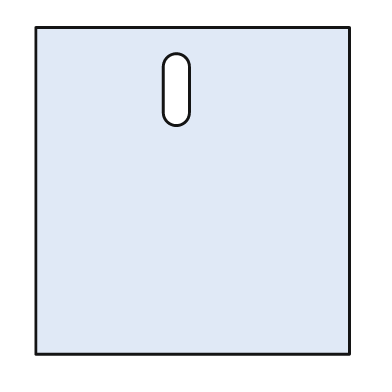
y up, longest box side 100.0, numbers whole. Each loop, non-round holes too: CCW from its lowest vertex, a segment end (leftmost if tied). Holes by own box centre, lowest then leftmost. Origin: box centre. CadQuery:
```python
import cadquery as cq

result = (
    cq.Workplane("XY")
    .moveTo(-48.0, -50.0)
    .lineTo(48.0, -50.0)
    .lineTo(48.0, 50.0)
    .lineTo(-48.0, 50.0)
    .close()
    .moveTo(-9.0, 24.0)
    .threePointArc((-5.0, 20.0), (-1.0, 24.0))
    .lineTo(-1.0, 38.0)
    .threePointArc((-5.0, 42.0), (-9.0, 38.0))
    .close()
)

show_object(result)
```